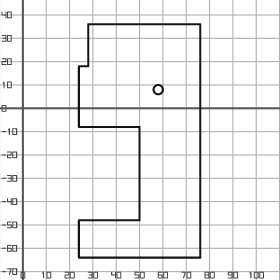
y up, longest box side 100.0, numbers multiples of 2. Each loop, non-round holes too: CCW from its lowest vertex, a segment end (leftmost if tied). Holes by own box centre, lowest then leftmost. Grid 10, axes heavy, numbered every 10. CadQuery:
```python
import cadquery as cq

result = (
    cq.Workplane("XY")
    .moveTo(24.0, -64.0)
    .lineTo(76.0, -64.0)
    .lineTo(76.0, 36.0)
    .lineTo(28.0, 36.0)
    .lineTo(28.0, 18.0)
    .lineTo(24.0, 18.0)
    .lineTo(24.0, -8.0)
    .lineTo(50.0, -8.0)
    .lineTo(50.0, -48.0)
    .lineTo(24.0, -48.0)
    .close()
    .moveTo(58.0, 8.0)
    .circle(2.0)
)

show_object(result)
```